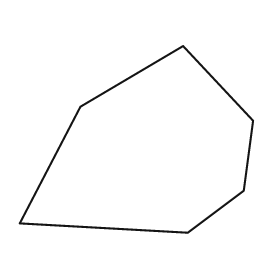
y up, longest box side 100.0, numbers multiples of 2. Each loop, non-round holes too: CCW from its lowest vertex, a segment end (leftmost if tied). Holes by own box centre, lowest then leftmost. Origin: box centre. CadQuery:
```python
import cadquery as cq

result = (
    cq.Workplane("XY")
    .moveTo(22.0, -40.0)
    .lineTo(46.0, -22.0)
    .lineTo(50.0, 8.0)
    .lineTo(20.0, 40.0)
    .lineTo(-24.0, 14.0)
    .lineTo(-50.0, -36.0)
    .close()
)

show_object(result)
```